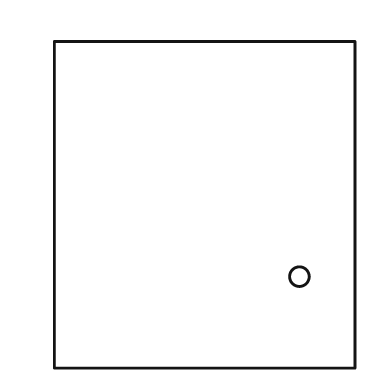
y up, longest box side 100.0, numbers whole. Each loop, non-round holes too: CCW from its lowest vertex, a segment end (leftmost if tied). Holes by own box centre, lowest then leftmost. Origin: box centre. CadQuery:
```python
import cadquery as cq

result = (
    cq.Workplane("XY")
    .moveTo(-46.0, -50.0)
    .lineTo(46.0, -50.0)
    .lineTo(46.0, 50.0)
    .lineTo(-46.0, 50.0)
    .close()
    .moveTo(29.0, -22.0)
    .circle(3.0)
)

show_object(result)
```